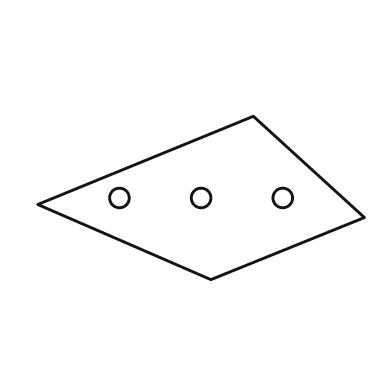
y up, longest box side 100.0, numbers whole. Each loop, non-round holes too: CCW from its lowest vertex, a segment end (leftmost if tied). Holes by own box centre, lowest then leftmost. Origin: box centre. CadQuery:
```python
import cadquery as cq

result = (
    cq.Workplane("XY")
    .moveTo(3.0, -25.0)
    .lineTo(50.0, -6.0)
    .lineTo(16.0, 25.0)
    .lineTo(-50.0, -2.0)
    .close()
    .moveTo(-25.0, 0.0)
    .circle(3.0)
    .moveTo(0.0, 0.0)
    .circle(3.0)
    .moveTo(25.0, 0.0)
    .circle(3.0)
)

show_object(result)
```